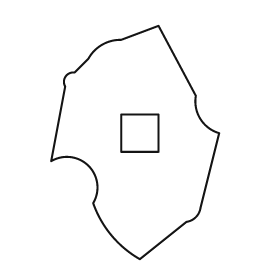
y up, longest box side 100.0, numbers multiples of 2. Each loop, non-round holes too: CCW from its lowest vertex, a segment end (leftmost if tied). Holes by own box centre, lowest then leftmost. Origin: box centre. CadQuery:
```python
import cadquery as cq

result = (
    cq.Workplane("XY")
    .moveTo(2.0, -50.0)
    .lineTo(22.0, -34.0)
    .threePointArc((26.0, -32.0), (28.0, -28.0))
    .lineTo(36.0, 4.0)
    .threePointArc((28.0, 10.0), (26.0, 20.0))
    .lineTo(10.0, 50.0)
    .lineTo(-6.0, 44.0)
    .threePointArc((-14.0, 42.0), (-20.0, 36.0))
    .lineTo(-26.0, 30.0)
    .threePointArc((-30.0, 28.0), (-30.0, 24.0))
    .lineTo(-36.0, -8.0)
    .threePointArc((-20.0, -10.0), (-18.0, -26.0))
    .threePointArc((-10.0, -40.0), (2.0, -50.0))
    .close()
    .moveTo(-6.0, -4.0)
    .lineTo(10.0, -4.0)
    .lineTo(10.0, 12.0)
    .lineTo(-6.0, 12.0)
    .close()
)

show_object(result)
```